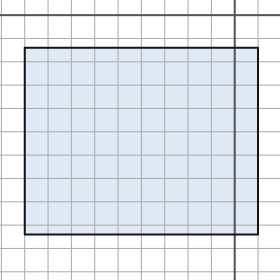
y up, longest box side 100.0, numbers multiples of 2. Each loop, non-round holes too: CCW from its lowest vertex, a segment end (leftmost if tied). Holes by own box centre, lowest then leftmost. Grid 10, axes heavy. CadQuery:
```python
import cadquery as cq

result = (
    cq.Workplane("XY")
    .moveTo(-90.0, -94.0)
    .lineTo(10.0, -94.0)
    .lineTo(10.0, -14.0)
    .lineTo(-90.0, -14.0)
    .close()
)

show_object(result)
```